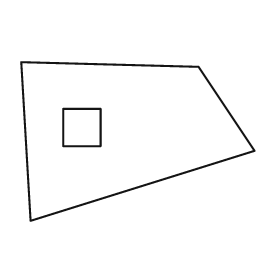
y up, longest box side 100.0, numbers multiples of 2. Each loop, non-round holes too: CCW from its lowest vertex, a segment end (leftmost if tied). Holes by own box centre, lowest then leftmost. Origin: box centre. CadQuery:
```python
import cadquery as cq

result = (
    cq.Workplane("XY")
    .moveTo(-46.0, -34.0)
    .lineTo(50.0, -4.0)
    .lineTo(26.0, 32.0)
    .lineTo(-50.0, 34.0)
    .close()
    .moveTo(-32.0, -2.0)
    .lineTo(-16.0, -2.0)
    .lineTo(-16.0, 14.0)
    .lineTo(-32.0, 14.0)
    .close()
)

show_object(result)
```